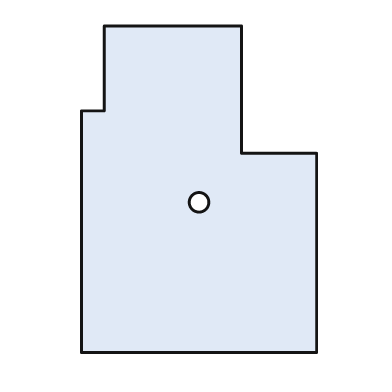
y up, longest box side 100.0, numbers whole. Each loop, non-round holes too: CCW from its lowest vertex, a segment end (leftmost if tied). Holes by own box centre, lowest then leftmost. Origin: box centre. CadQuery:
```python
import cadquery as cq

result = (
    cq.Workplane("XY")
    .moveTo(-36.0, -50.0)
    .lineTo(36.0, -50.0)
    .lineTo(36.0, 11.0)
    .lineTo(13.0, 11.0)
    .lineTo(13.0, 50.0)
    .lineTo(-29.0, 50.0)
    .lineTo(-29.0, 24.0)
    .lineTo(-36.0, 24.0)
    .close()
    .moveTo(0.0, -4.0)
    .circle(3.0)
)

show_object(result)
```